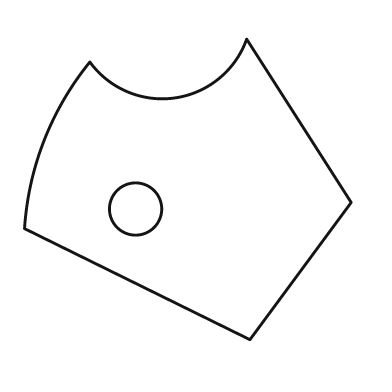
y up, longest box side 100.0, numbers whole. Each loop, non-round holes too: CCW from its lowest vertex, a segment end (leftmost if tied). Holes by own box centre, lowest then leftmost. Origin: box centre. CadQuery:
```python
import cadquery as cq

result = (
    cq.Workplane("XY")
    .moveTo(19.0, -46.0)
    .lineTo(50.0, -4.0)
    .lineTo(18.0, 46.0)
    .threePointArc((-4.0, 28.0), (-30.0, 39.0))
    .threePointArc((-44.0, 15.0), (-50.0, -12.0))
    .close()
    .moveTo(-16.0, -6.0)
    .circle(8.0)
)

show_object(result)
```